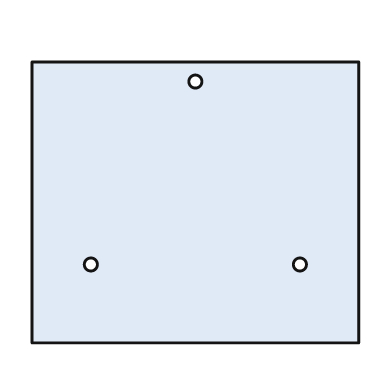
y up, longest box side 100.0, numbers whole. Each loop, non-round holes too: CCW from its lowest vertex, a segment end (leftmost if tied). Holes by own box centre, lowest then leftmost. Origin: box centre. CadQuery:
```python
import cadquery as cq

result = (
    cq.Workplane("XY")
    .moveTo(-50.0, -43.0)
    .lineTo(50.0, -43.0)
    .lineTo(50.0, 43.0)
    .lineTo(-50.0, 43.0)
    .close()
    .moveTo(-32.0, -19.0)
    .circle(2.0)
    .moveTo(32.0, -19.0)
    .circle(2.0)
    .moveTo(0.0, 37.0)
    .circle(2.0)
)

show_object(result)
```